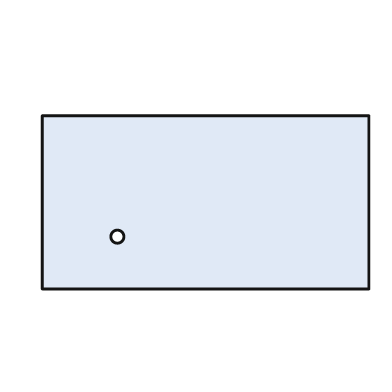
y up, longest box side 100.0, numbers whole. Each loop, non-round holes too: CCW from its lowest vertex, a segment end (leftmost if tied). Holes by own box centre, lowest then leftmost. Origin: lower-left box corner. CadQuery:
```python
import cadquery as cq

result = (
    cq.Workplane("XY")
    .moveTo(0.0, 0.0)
    .lineTo(100.0, 0.0)
    .lineTo(100.0, 53.0)
    .lineTo(0.0, 53.0)
    .close()
    .moveTo(23.0, 16.0)
    .circle(2.0)
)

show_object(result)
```